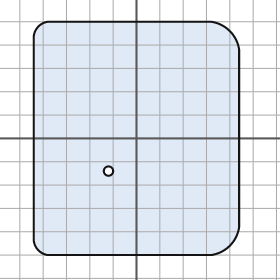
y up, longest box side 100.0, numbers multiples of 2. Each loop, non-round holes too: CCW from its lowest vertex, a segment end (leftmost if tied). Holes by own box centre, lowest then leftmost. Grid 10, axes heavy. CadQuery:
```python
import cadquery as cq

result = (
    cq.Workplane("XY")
    .moveTo(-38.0, -50.0)
    .lineTo(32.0, -50.0)
    .threePointArc((40.0, -46.0), (44.0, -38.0))
    .lineTo(44.0, 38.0)
    .threePointArc((40.0, 46.0), (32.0, 50.0))
    .lineTo(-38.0, 50.0)
    .threePointArc((-42.0, 48.0), (-44.0, 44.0))
    .lineTo(-44.0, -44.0)
    .threePointArc((-42.0, -48.0), (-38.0, -50.0))
    .close()
    .moveTo(-12.0, -14.0)
    .circle(2.0)
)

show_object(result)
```